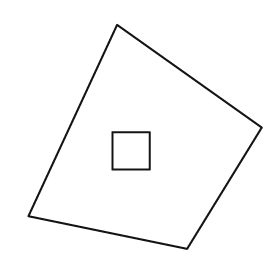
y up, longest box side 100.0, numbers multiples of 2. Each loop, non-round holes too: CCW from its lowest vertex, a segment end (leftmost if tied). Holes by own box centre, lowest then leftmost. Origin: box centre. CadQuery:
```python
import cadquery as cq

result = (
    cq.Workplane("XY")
    .moveTo(18.0, -48.0)
    .lineTo(50.0, 4.0)
    .lineTo(-12.0, 48.0)
    .lineTo(-50.0, -34.0)
    .close()
    .moveTo(-14.0, -14.0)
    .lineTo(2.0, -14.0)
    .lineTo(2.0, 2.0)
    .lineTo(-14.0, 2.0)
    .close()
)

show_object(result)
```